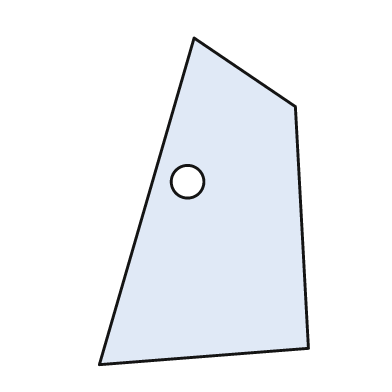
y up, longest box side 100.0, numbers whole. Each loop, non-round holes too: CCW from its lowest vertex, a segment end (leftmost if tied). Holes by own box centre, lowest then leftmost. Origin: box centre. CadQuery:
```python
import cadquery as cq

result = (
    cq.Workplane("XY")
    .moveTo(-32.0, -50.0)
    .lineTo(32.0, -45.0)
    .lineTo(28.0, 29.0)
    .lineTo(-3.0, 50.0)
    .close()
    .moveTo(-5.0, 6.0)
    .circle(5.0)
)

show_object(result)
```